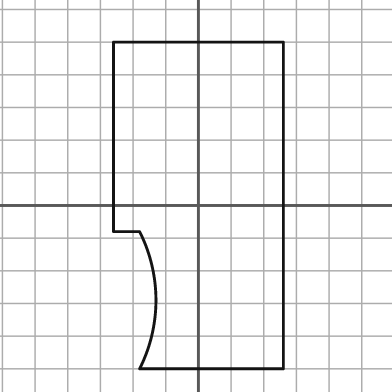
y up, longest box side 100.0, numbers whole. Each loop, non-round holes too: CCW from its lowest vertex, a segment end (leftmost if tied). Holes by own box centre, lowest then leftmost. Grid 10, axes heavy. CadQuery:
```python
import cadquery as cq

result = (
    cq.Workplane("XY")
    .moveTo(-18.0, -50.0)
    .lineTo(26.0, -50.0)
    .lineTo(26.0, 50.0)
    .lineTo(-26.0, 50.0)
    .lineTo(-26.0, -8.0)
    .lineTo(-18.0, -8.0)
    .threePointArc((-13.0, -29.0), (-18.0, -50.0))
    .close()
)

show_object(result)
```